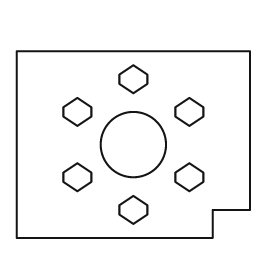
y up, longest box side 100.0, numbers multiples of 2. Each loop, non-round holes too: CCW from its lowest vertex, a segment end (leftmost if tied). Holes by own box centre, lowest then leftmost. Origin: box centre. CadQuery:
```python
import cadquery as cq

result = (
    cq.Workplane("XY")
    .moveTo(-50.0, -40.0)
    .lineTo(34.0, -40.0)
    .lineTo(34.0, -28.0)
    .lineTo(50.0, -28.0)
    .lineTo(50.0, 40.0)
    .lineTo(-50.0, 40.0)
    .close()
    .moveTo(0.0, -34.0)
    .lineTo(6.0, -30.0)
    .lineTo(6.0, -26.0)
    .lineTo(0.0, -22.0)
    .lineTo(-6.0, -26.0)
    .lineTo(-6.0, -30.0)
    .close()
    .moveTo(-24.0, -20.0)
    .lineTo(-18.0, -16.0)
    .lineTo(-18.0, -12.0)
    .lineTo(-24.0, -8.0)
    .lineTo(-30.0, -12.0)
    .lineTo(-30.0, -16.0)
    .close()
    .moveTo(24.0, -20.0)
    .lineTo(30.0, -16.0)
    .lineTo(30.0, -12.0)
    .lineTo(24.0, -8.0)
    .lineTo(18.0, -12.0)
    .lineTo(18.0, -16.0)
    .close()
    .moveTo(0.0, 0.0)
    .circle(14.0)
    .moveTo(-24.0, 8.0)
    .lineTo(-18.0, 12.0)
    .lineTo(-18.0, 16.0)
    .lineTo(-24.0, 20.0)
    .lineTo(-30.0, 16.0)
    .lineTo(-30.0, 12.0)
    .close()
    .moveTo(24.0, 8.0)
    .lineTo(30.0, 12.0)
    .lineTo(30.0, 16.0)
    .lineTo(24.0, 20.0)
    .lineTo(18.0, 16.0)
    .lineTo(18.0, 12.0)
    .close()
    .moveTo(0.0, 22.0)
    .lineTo(6.0, 26.0)
    .lineTo(6.0, 30.0)
    .lineTo(0.0, 34.0)
    .lineTo(-6.0, 30.0)
    .lineTo(-6.0, 26.0)
    .close()
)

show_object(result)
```